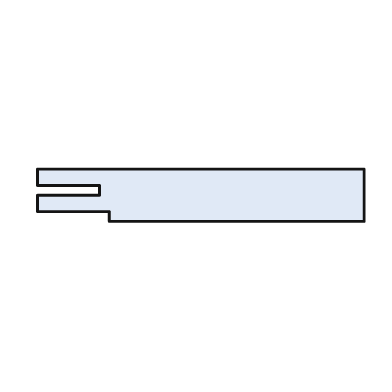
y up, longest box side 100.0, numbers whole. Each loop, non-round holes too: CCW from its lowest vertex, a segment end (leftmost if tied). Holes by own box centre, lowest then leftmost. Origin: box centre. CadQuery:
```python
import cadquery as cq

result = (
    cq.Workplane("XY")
    .moveTo(-28.0, -8.0)
    .lineTo(50.0, -8.0)
    .lineTo(50.0, 8.0)
    .lineTo(-50.0, 8.0)
    .lineTo(-50.0, 3.0)
    .lineTo(-31.0, 3.0)
    .lineTo(-31.0, 0.0)
    .lineTo(-50.0, 0.0)
    .lineTo(-50.0, -5.0)
    .lineTo(-28.0, -5.0)
    .close()
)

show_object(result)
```